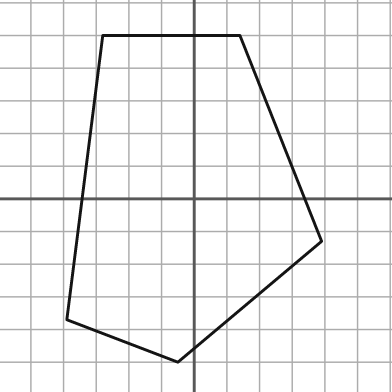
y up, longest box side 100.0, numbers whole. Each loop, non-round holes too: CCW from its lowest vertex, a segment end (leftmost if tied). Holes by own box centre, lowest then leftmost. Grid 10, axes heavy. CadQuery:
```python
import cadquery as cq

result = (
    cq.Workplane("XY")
    .moveTo(-5.0, -50.0)
    .lineTo(39.0, -13.0)
    .lineTo(14.0, 50.0)
    .lineTo(-28.0, 50.0)
    .lineTo(-39.0, -37.0)
    .close()
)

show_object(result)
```